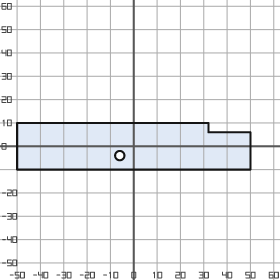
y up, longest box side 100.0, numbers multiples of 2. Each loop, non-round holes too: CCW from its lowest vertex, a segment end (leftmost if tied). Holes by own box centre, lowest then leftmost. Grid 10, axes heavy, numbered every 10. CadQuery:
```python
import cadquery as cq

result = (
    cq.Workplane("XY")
    .moveTo(-50.0, -10.0)
    .lineTo(50.0, -10.0)
    .lineTo(50.0, 6.0)
    .lineTo(32.0, 6.0)
    .lineTo(32.0, 10.0)
    .lineTo(-50.0, 10.0)
    .close()
    .moveTo(-6.0, -4.0)
    .circle(2.0)
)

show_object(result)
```